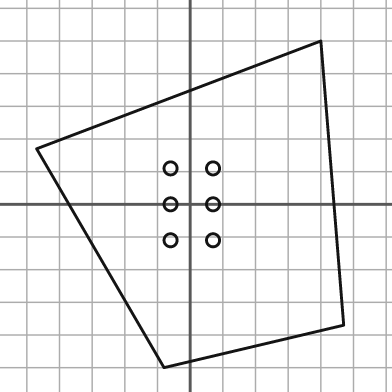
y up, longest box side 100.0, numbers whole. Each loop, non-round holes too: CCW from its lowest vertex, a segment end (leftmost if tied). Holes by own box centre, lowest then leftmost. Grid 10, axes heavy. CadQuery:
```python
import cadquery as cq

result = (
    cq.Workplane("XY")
    .moveTo(-8.0, -50.0)
    .lineTo(47.0, -37.0)
    .lineTo(40.0, 50.0)
    .lineTo(-47.0, 17.0)
    .close()
    .moveTo(-6.0, -11.0)
    .circle(2.0)
    .moveTo(7.0, -11.0)
    .circle(2.0)
    .moveTo(-6.0, 0.0)
    .circle(2.0)
    .moveTo(7.0, 0.0)
    .circle(2.0)
    .moveTo(-6.0, 11.0)
    .circle(2.0)
    .moveTo(7.0, 11.0)
    .circle(2.0)
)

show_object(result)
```